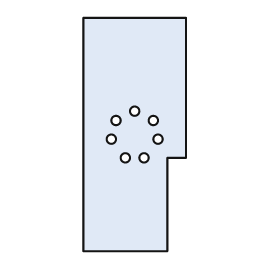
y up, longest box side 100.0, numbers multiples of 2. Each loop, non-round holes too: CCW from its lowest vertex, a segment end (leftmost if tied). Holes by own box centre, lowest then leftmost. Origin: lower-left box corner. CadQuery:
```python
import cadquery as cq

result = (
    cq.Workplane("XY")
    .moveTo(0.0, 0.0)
    .lineTo(36.0, 0.0)
    .lineTo(36.0, 40.0)
    .lineTo(44.0, 40.0)
    .lineTo(44.0, 100.0)
    .lineTo(0.0, 100.0)
    .close()
    .moveTo(18.0, 40.0)
    .circle(2.0)
    .moveTo(26.0, 40.0)
    .circle(2.0)
    .moveTo(12.0, 48.0)
    .circle(2.0)
    .moveTo(32.0, 48.0)
    .circle(2.0)
    .moveTo(14.0, 56.0)
    .circle(2.0)
    .moveTo(30.0, 56.0)
    .circle(2.0)
    .moveTo(22.0, 60.0)
    .circle(2.0)
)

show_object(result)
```